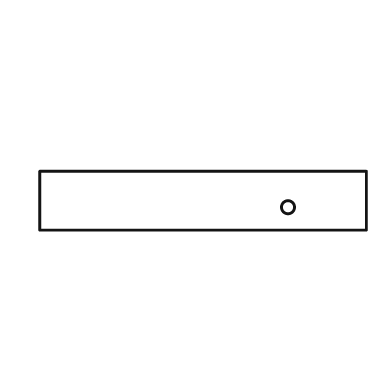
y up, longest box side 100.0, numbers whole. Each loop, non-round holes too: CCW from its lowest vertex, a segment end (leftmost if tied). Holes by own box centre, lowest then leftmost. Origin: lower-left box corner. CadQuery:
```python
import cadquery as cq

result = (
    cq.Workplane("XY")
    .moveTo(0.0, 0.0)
    .lineTo(100.0, 0.0)
    .lineTo(100.0, 18.0)
    .lineTo(0.0, 18.0)
    .close()
    .moveTo(76.0, 7.0)
    .circle(2.0)
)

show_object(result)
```